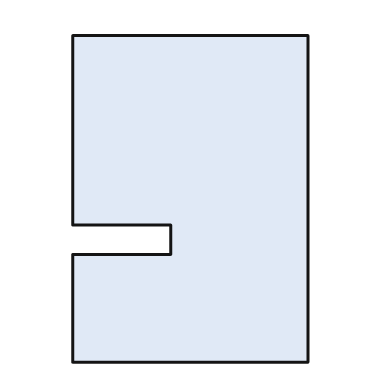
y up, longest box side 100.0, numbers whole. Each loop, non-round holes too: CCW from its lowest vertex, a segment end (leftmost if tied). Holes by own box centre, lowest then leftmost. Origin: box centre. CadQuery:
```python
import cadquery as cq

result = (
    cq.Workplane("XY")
    .moveTo(-36.0, -50.0)
    .lineTo(36.0, -50.0)
    .lineTo(36.0, 50.0)
    .lineTo(-36.0, 50.0)
    .lineTo(-36.0, -8.0)
    .lineTo(-6.0, -8.0)
    .lineTo(-6.0, -17.0)
    .lineTo(-36.0, -17.0)
    .close()
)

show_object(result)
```